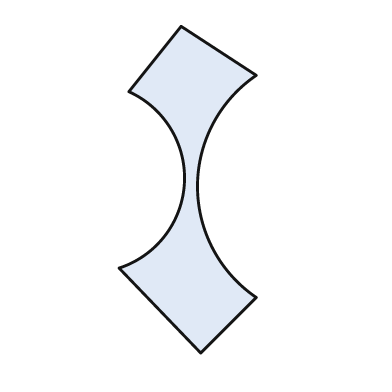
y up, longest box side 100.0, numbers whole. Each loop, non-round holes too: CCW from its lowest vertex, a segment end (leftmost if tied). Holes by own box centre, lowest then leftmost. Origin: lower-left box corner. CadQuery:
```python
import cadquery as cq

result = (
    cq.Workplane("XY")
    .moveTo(25.0, 0.0)
    .lineTo(42.0, 17.0)
    .threePointArc((24.0, 51.0), (42.0, 85.0))
    .lineTo(19.0, 100.0)
    .lineTo(3.0, 80.0)
    .threePointArc((20.0, 52.0), (0.0, 26.0))
    .close()
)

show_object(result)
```